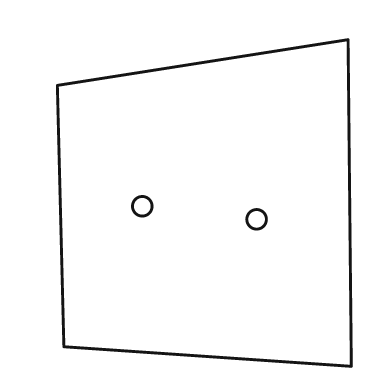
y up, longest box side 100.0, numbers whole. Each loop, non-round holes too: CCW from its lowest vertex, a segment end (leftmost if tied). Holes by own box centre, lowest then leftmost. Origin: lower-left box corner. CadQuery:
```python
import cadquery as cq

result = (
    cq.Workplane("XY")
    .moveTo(90.0, 0.0)
    .lineTo(89.0, 100.0)
    .lineTo(0.0, 86.0)
    .lineTo(2.0, 6.0)
    .close()
    .moveTo(61.0, 45.0)
    .circle(3.0)
    .moveTo(26.0, 49.0)
    .circle(3.0)
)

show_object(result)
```